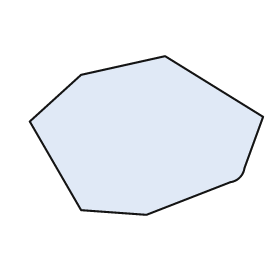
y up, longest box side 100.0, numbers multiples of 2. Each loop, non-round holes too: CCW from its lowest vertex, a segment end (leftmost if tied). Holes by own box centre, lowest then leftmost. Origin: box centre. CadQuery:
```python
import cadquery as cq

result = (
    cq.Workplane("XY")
    .moveTo(0.0, -34.0)
    .lineTo(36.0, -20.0)
    .threePointArc((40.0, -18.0), (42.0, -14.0))
    .lineTo(50.0, 8.0)
    .lineTo(8.0, 34.0)
    .lineTo(-28.0, 26.0)
    .lineTo(-50.0, 6.0)
    .lineTo(-28.0, -32.0)
    .close()
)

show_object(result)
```